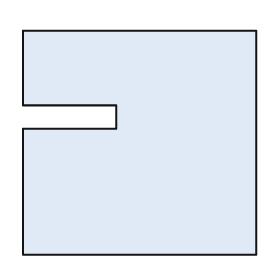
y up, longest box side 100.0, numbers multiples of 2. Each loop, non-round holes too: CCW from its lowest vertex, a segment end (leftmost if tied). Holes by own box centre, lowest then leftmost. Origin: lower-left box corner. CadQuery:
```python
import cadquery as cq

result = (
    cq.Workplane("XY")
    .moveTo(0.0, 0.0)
    .lineTo(100.0, 0.0)
    .lineTo(100.0, 96.0)
    .lineTo(0.0, 96.0)
    .lineTo(0.0, 64.0)
    .lineTo(40.0, 64.0)
    .lineTo(40.0, 54.0)
    .lineTo(0.0, 54.0)
    .close()
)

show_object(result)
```